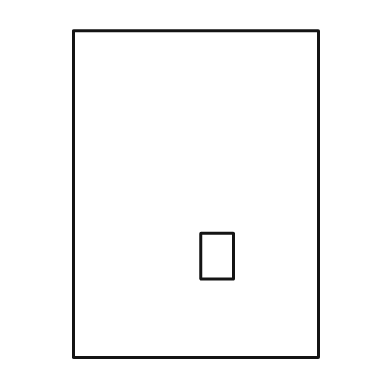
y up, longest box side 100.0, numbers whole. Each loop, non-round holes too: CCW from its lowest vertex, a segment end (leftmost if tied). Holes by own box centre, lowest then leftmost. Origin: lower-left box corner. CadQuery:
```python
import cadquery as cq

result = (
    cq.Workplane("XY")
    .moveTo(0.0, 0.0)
    .lineTo(75.0, 0.0)
    .lineTo(75.0, 100.0)
    .lineTo(0.0, 100.0)
    .close()
    .moveTo(39.0, 24.0)
    .lineTo(49.0, 24.0)
    .lineTo(49.0, 38.0)
    .lineTo(39.0, 38.0)
    .close()
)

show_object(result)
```